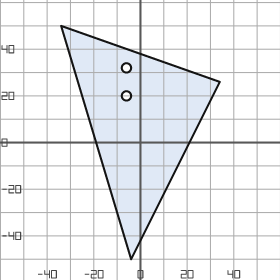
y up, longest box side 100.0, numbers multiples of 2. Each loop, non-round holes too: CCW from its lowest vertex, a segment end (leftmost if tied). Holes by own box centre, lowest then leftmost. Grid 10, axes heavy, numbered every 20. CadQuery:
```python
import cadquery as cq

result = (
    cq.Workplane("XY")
    .moveTo(-4.0, -50.0)
    .lineTo(34.0, 26.0)
    .lineTo(-34.0, 50.0)
    .close()
    .moveTo(-6.0, 20.0)
    .circle(2.0)
    .moveTo(-6.0, 32.0)
    .circle(2.0)
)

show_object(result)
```